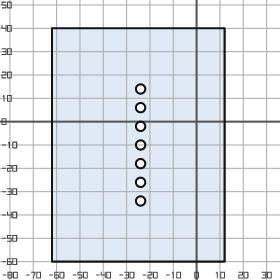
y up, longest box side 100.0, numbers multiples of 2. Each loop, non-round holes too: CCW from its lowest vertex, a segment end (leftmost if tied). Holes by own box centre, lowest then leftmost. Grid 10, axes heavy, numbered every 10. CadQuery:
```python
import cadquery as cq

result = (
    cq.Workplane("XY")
    .moveTo(-62.0, -60.0)
    .lineTo(12.0, -60.0)
    .lineTo(12.0, 40.0)
    .lineTo(-62.0, 40.0)
    .close()
    .moveTo(-24.0, -34.0)
    .circle(2.0)
    .moveTo(-24.0, -26.0)
    .circle(2.0)
    .moveTo(-24.0, -18.0)
    .circle(2.0)
    .moveTo(-24.0, -10.0)
    .circle(2.0)
    .moveTo(-24.0, -2.0)
    .circle(2.0)
    .moveTo(-24.0, 6.0)
    .circle(2.0)
    .moveTo(-24.0, 14.0)
    .circle(2.0)
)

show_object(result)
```